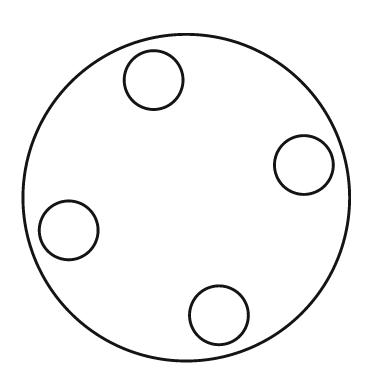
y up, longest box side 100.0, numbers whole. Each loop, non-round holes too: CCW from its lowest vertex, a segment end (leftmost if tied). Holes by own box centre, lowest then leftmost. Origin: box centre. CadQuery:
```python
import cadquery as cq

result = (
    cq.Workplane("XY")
    .moveTo(0.0, 0.0)
    .circle(50.0)
    .moveTo(10.0, -36.0)
    .circle(9.0)
    .moveTo(-36.0, -10.0)
    .circle(9.0)
    .moveTo(36.0, 10.0)
    .circle(9.0)
    .moveTo(-10.0, 36.0)
    .circle(9.0)
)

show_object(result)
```